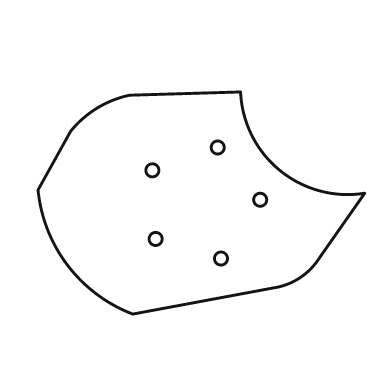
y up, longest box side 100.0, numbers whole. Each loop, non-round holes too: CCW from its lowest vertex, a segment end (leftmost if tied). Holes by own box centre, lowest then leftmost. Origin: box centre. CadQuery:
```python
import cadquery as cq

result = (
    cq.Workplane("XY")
    .moveTo(-21.0, -34.0)
    .lineTo(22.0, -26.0)
    .threePointArc((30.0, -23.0), (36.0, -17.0))
    .lineTo(50.0, 3.0)
    .threePointArc((24.0, 10.0), (12.0, 34.0))
    .lineTo(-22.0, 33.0)
    .threePointArc((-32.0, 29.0), (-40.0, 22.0))
    .lineTo(-50.0, 4.0)
    .threePointArc((-41.0, -19.0), (-21.0, -34.0))
    .close()
    .moveTo(6.0, -17.0)
    .circle(2.0)
    .moveTo(-14.0, -11.0)
    .circle(2.0)
    .moveTo(18.0, 1.0)
    .circle(2.0)
    .moveTo(-15.0, 10.0)
    .circle(2.0)
    .moveTo(5.0, 17.0)
    .circle(2.0)
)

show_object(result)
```